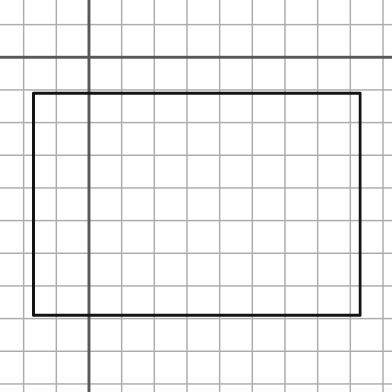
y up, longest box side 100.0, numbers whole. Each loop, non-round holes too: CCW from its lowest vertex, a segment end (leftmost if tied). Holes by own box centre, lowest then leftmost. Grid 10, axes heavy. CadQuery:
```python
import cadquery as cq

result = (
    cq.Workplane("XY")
    .moveTo(-17.0, -79.0)
    .lineTo(83.0, -79.0)
    .lineTo(83.0, -11.0)
    .lineTo(-17.0, -11.0)
    .close()
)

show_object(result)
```